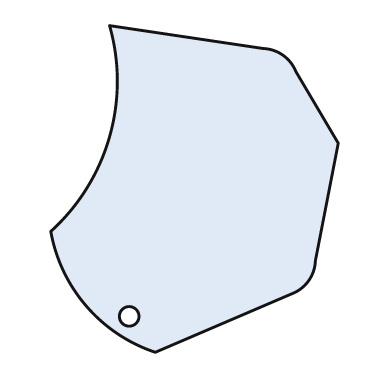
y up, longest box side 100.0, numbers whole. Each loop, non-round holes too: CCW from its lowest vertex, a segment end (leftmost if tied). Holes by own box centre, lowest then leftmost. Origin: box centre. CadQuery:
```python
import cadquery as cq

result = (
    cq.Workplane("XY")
    .moveTo(-12.0, -50.0)
    .lineTo(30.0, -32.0)
    .threePointArc((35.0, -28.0), (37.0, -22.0))
    .lineTo(44.0, 14.0)
    .lineTo(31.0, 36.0)
    .threePointArc((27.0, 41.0), (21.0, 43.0))
    .lineTo(-26.0, 50.0)
    .threePointArc((-26.0, 16.0), (-44.0, -13.0))
    .threePointArc((-33.0, -36.0), (-12.0, -50.0))
    .close()
    .moveTo(-20.0, -39.0)
    .circle(3.0)
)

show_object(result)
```